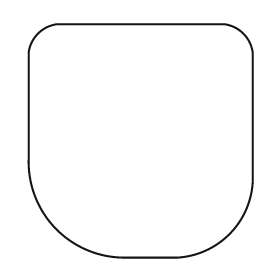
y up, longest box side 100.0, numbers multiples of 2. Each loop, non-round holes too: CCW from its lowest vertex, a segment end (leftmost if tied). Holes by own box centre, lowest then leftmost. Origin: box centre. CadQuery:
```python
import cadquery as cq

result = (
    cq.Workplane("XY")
    .moveTo(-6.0, -50.0)
    .lineTo(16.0, -50.0)
    .threePointArc((38.0, -40.0), (48.0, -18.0))
    .lineTo(48.0, 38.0)
    .threePointArc((44.0, 46.0), (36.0, 50.0))
    .lineTo(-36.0, 50.0)
    .threePointArc((-44.0, 46.0), (-48.0, 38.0))
    .lineTo(-48.0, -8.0)
    .threePointArc((-36.0, -38.0), (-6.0, -50.0))
    .close()
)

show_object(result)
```